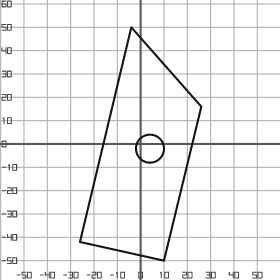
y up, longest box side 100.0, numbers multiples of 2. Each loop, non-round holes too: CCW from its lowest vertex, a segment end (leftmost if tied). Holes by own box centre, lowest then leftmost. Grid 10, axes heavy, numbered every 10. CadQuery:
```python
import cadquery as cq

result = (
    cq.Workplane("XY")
    .moveTo(10.0, -50.0)
    .lineTo(26.0, 16.0)
    .lineTo(-4.0, 50.0)
    .lineTo(-26.0, -42.0)
    .close()
    .moveTo(4.0, -2.0)
    .circle(6.0)
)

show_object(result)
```